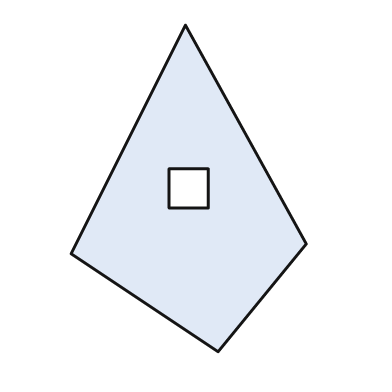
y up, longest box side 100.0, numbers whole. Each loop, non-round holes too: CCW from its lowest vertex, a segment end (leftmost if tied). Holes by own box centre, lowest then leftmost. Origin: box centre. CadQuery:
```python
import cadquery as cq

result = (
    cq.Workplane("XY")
    .moveTo(9.0, -50.0)
    .lineTo(36.0, -17.0)
    .lineTo(-1.0, 50.0)
    .lineTo(-36.0, -20.0)
    .close()
    .moveTo(-6.0, -6.0)
    .lineTo(6.0, -6.0)
    .lineTo(6.0, 6.0)
    .lineTo(-6.0, 6.0)
    .close()
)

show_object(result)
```